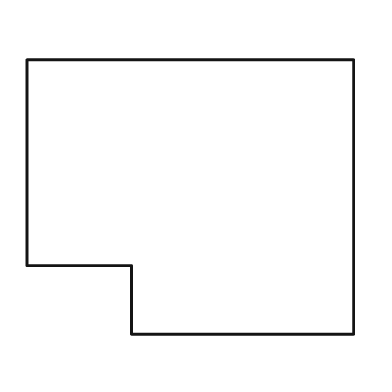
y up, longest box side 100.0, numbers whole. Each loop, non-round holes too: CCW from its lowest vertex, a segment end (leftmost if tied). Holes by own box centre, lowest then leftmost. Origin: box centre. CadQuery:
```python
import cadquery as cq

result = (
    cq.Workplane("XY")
    .moveTo(-18.0, -42.0)
    .lineTo(50.0, -42.0)
    .lineTo(50.0, 42.0)
    .lineTo(-50.0, 42.0)
    .lineTo(-50.0, -21.0)
    .lineTo(-18.0, -21.0)
    .close()
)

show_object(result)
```